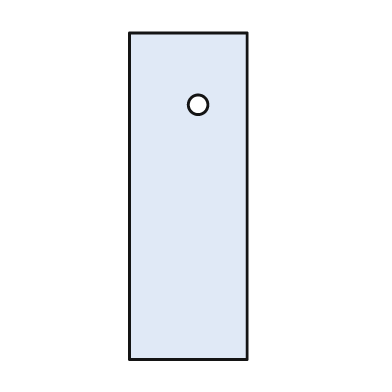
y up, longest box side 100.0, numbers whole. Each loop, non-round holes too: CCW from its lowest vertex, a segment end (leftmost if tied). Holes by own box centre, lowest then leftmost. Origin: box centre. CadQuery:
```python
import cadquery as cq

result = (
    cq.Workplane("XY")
    .moveTo(-18.0, -50.0)
    .lineTo(18.0, -50.0)
    .lineTo(18.0, 50.0)
    .lineTo(-18.0, 50.0)
    .close()
    .moveTo(3.0, 28.0)
    .circle(3.0)
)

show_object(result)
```